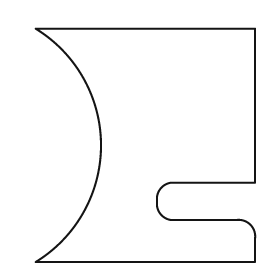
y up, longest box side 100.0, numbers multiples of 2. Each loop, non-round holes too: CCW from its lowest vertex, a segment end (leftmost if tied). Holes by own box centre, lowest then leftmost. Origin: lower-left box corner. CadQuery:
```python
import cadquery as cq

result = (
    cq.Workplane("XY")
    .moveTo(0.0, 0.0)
    .lineTo(94.0, 0.0)
    .lineTo(94.0, 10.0)
    .threePointArc((92.0, 16.0), (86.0, 18.0))
    .lineTo(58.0, 18.0)
    .threePointArc((54.0, 20.0), (52.0, 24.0))
    .lineTo(52.0, 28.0)
    .threePointArc((54.0, 32.0), (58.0, 34.0))
    .lineTo(94.0, 34.0)
    .lineTo(94.0, 100.0)
    .lineTo(0.0, 100.0)
    .threePointArc((28.0, 50.0), (0.0, 0.0))
    .close()
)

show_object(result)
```